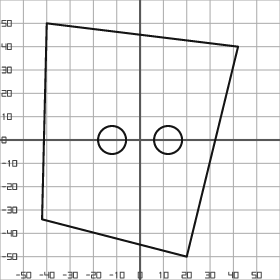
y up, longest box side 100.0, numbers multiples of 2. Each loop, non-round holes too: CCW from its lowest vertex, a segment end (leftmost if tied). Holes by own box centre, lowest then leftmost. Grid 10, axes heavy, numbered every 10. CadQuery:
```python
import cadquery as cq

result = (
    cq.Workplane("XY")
    .moveTo(20.0, -50.0)
    .lineTo(42.0, 40.0)
    .lineTo(-40.0, 50.0)
    .lineTo(-42.0, -34.0)
    .close()
    .moveTo(-12.0, 0.0)
    .circle(6.0)
    .moveTo(12.0, 0.0)
    .circle(6.0)
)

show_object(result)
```